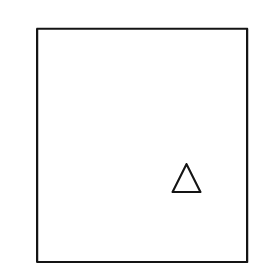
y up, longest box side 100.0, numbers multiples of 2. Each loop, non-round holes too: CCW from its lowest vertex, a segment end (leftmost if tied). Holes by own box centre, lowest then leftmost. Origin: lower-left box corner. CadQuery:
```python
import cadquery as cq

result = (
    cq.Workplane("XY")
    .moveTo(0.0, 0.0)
    .lineTo(90.0, 0.0)
    .lineTo(90.0, 100.0)
    .lineTo(0.0, 100.0)
    .close()
    .moveTo(58.0, 30.0)
    .lineTo(70.0, 30.0)
    .lineTo(64.0, 42.0)
    .close()
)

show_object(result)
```